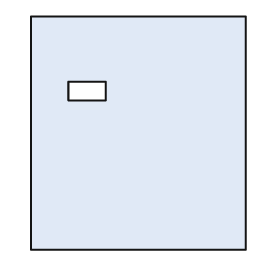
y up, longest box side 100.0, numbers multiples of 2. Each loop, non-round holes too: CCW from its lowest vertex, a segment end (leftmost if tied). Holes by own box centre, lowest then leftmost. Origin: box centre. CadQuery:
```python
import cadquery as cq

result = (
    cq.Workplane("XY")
    .moveTo(-46.0, -50.0)
    .lineTo(46.0, -50.0)
    .lineTo(46.0, 50.0)
    .lineTo(-46.0, 50.0)
    .close()
    .moveTo(-30.0, 14.0)
    .lineTo(-14.0, 14.0)
    .lineTo(-14.0, 22.0)
    .lineTo(-30.0, 22.0)
    .close()
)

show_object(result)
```